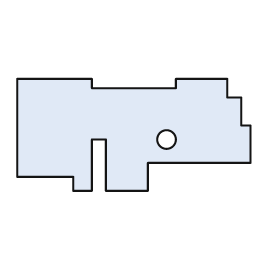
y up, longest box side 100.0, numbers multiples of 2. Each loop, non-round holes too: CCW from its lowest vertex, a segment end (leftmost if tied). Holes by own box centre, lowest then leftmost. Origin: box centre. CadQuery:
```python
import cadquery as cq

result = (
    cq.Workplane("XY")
    .moveTo(-26.0, -24.0)
    .lineTo(-18.0, -24.0)
    .lineTo(-18.0, -2.0)
    .lineTo(-12.0, -2.0)
    .lineTo(-12.0, -24.0)
    .lineTo(6.0, -24.0)
    .lineTo(6.0, -12.0)
    .lineTo(50.0, -12.0)
    .lineTo(50.0, 4.0)
    .lineTo(46.0, 4.0)
    .lineTo(46.0, 16.0)
    .lineTo(40.0, 16.0)
    .lineTo(40.0, 24.0)
    .lineTo(18.0, 24.0)
    .lineTo(18.0, 20.0)
    .lineTo(-18.0, 20.0)
    .lineTo(-18.0, 24.0)
    .lineTo(-50.0, 24.0)
    .lineTo(-50.0, -18.0)
    .lineTo(-26.0, -18.0)
    .close()
    .moveTo(14.0, -2.0)
    .circle(4.0)
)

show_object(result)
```